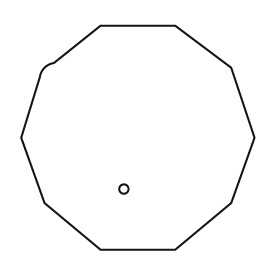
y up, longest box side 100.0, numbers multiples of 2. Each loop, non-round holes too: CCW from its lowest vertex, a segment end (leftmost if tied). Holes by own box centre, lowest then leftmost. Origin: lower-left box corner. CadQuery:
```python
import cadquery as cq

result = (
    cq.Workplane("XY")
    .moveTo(34.0, 0.0)
    .lineTo(66.0, 0.0)
    .lineTo(90.0, 20.0)
    .lineTo(100.0, 48.0)
    .lineTo(90.0, 78.0)
    .lineTo(66.0, 96.0)
    .lineTo(34.0, 96.0)
    .lineTo(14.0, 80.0)
    .threePointArc((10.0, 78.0), (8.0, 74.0))
    .lineTo(0.0, 48.0)
    .lineTo(10.0, 20.0)
    .close()
    .moveTo(44.0, 26.0)
    .circle(2.0)
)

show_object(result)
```